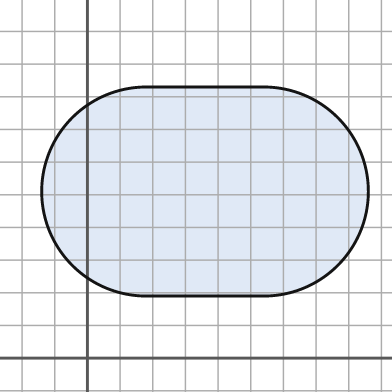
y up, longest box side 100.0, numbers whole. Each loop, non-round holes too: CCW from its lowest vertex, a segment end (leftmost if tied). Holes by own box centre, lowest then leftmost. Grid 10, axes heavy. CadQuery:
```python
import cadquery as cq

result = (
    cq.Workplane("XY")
    .moveTo(18.0, 19.0)
    .lineTo(54.0, 19.0)
    .threePointArc((86.0, 51.0), (54.0, 83.0))
    .lineTo(18.0, 83.0)
    .threePointArc((-14.0, 51.0), (18.0, 19.0))
    .close()
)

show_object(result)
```